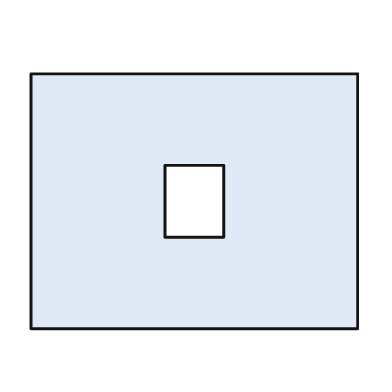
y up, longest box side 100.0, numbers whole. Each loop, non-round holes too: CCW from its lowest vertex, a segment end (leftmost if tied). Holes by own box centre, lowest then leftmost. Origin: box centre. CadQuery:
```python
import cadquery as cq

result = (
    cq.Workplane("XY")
    .moveTo(-50.0, -39.0)
    .lineTo(50.0, -39.0)
    .lineTo(50.0, 39.0)
    .lineTo(-50.0, 39.0)
    .close()
    .moveTo(-9.0, -11.0)
    .lineTo(9.0, -11.0)
    .lineTo(9.0, 11.0)
    .lineTo(-9.0, 11.0)
    .close()
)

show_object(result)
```